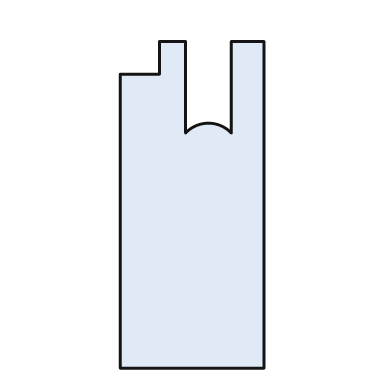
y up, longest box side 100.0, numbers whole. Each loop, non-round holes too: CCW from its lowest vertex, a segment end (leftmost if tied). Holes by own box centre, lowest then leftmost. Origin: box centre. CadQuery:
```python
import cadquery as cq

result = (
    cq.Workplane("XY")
    .moveTo(-22.0, -50.0)
    .lineTo(22.0, -50.0)
    .lineTo(22.0, 50.0)
    .lineTo(12.0, 50.0)
    .lineTo(12.0, 22.0)
    .threePointArc((5.0, 25.0), (-2.0, 22.0))
    .lineTo(-2.0, 50.0)
    .lineTo(-10.0, 50.0)
    .lineTo(-10.0, 40.0)
    .lineTo(-22.0, 40.0)
    .close()
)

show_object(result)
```